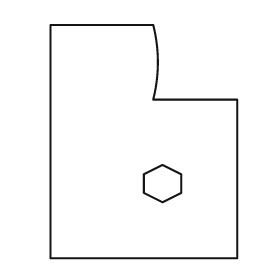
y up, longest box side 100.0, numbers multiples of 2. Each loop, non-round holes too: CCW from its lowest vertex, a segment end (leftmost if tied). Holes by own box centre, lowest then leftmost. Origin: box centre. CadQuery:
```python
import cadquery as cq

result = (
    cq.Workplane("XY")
    .moveTo(-40.0, -50.0)
    .lineTo(40.0, -50.0)
    .lineTo(40.0, 18.0)
    .lineTo(4.0, 18.0)
    .threePointArc((6.0, 34.0), (4.0, 50.0))
    .lineTo(-40.0, 50.0)
    .close()
    .moveTo(8.0, -26.0)
    .lineTo(16.0, -22.0)
    .lineTo(16.0, -14.0)
    .lineTo(8.0, -10.0)
    .lineTo(0.0, -14.0)
    .lineTo(0.0, -22.0)
    .close()
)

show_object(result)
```